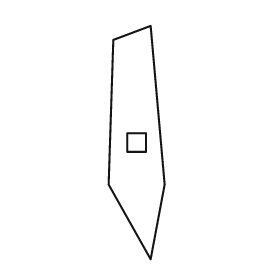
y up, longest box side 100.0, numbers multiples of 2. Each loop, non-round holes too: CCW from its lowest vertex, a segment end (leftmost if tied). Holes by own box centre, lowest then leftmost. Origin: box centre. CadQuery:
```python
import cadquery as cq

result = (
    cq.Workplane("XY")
    .moveTo(6.0, -50.0)
    .lineTo(12.0, -18.0)
    .lineTo(6.0, 50.0)
    .lineTo(-10.0, 44.0)
    .lineTo(-12.0, -18.0)
    .close()
    .moveTo(-4.0, -4.0)
    .lineTo(4.0, -4.0)
    .lineTo(4.0, 4.0)
    .lineTo(-4.0, 4.0)
    .close()
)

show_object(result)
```